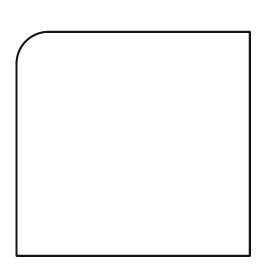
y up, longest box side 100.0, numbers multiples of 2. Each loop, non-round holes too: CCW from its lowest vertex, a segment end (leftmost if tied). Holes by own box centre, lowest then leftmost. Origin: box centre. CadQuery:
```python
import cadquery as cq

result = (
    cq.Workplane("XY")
    .moveTo(-50.0, -48.0)
    .lineTo(50.0, -48.0)
    .lineTo(50.0, 48.0)
    .lineTo(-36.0, 48.0)
    .threePointArc((-46.0, 44.0), (-50.0, 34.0))
    .close()
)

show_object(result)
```